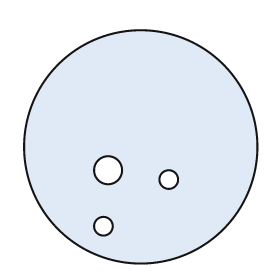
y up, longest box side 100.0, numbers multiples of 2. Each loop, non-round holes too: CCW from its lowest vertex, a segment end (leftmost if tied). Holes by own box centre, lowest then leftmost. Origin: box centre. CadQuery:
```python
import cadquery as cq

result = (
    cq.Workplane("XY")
    .moveTo(0.0, 0.0)
    .circle(50.0)
    .moveTo(-16.0, -34.0)
    .circle(4.0)
    .moveTo(12.0, -14.0)
    .circle(4.0)
    .moveTo(-14.0, -10.0)
    .circle(6.0)
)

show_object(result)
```